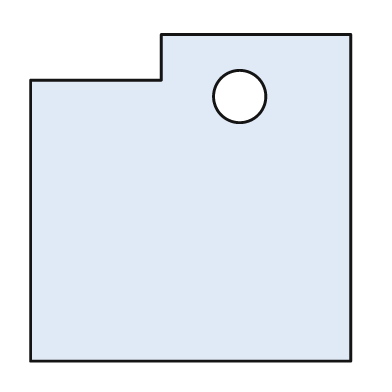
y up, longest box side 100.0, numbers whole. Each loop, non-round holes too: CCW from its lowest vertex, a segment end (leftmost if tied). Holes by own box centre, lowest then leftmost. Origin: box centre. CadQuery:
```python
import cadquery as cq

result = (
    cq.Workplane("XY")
    .moveTo(-49.0, -50.0)
    .lineTo(49.0, -50.0)
    .lineTo(49.0, 50.0)
    .lineTo(-9.0, 50.0)
    .lineTo(-9.0, 36.0)
    .lineTo(-49.0, 36.0)
    .close()
    .moveTo(15.0, 31.0)
    .circle(8.0)
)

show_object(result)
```